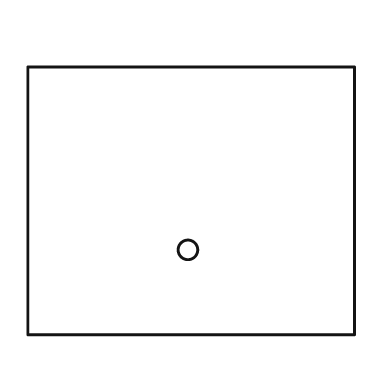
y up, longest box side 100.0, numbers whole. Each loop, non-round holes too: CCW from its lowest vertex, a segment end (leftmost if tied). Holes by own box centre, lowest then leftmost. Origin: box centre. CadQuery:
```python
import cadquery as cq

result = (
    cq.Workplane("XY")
    .moveTo(-50.0, -41.0)
    .lineTo(50.0, -41.0)
    .lineTo(50.0, 41.0)
    .lineTo(-50.0, 41.0)
    .close()
    .moveTo(-1.0, -15.0)
    .circle(3.0)
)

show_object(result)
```